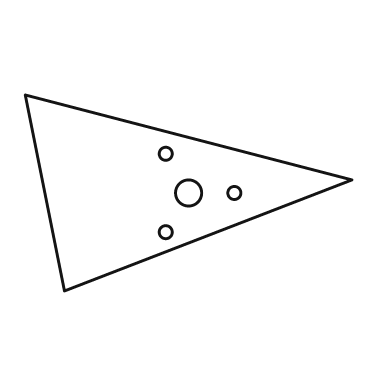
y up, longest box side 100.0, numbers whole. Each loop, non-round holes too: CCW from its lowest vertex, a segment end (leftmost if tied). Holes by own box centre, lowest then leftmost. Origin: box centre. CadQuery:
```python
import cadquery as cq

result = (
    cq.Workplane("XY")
    .moveTo(-38.0, -30.0)
    .lineTo(50.0, 4.0)
    .lineTo(-50.0, 30.0)
    .close()
    .moveTo(-7.0, -12.0)
    .circle(2.0)
    .moveTo(0.0, 0.0)
    .circle(4.0)
    .moveTo(14.0, 0.0)
    .circle(2.0)
    .moveTo(-7.0, 12.0)
    .circle(2.0)
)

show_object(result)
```